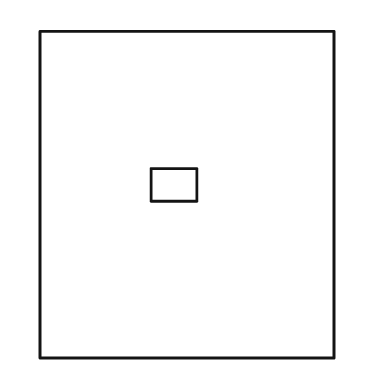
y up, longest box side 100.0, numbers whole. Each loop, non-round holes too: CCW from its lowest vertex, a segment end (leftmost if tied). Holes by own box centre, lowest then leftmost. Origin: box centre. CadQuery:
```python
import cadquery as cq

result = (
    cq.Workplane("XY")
    .moveTo(-45.0, -50.0)
    .lineTo(45.0, -50.0)
    .lineTo(45.0, 50.0)
    .lineTo(-45.0, 50.0)
    .close()
    .moveTo(-11.0, -2.0)
    .lineTo(3.0, -2.0)
    .lineTo(3.0, 8.0)
    .lineTo(-11.0, 8.0)
    .close()
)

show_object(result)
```